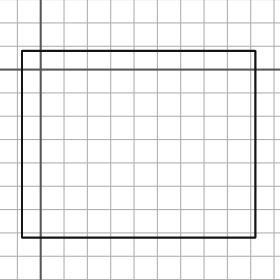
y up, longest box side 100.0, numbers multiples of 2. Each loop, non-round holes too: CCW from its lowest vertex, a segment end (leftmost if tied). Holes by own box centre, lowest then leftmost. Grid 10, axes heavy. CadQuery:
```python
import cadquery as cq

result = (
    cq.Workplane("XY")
    .moveTo(-8.0, -72.0)
    .lineTo(92.0, -72.0)
    .lineTo(92.0, 8.0)
    .lineTo(-8.0, 8.0)
    .close()
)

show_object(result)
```